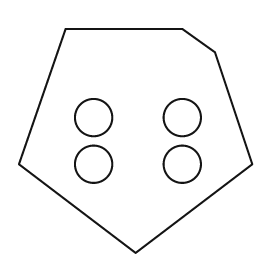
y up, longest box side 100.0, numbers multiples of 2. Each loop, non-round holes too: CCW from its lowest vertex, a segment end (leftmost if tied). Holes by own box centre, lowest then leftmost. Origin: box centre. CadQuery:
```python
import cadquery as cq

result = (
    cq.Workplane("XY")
    .moveTo(0.0, -48.0)
    .lineTo(50.0, -10.0)
    .lineTo(34.0, 38.0)
    .lineTo(20.0, 48.0)
    .lineTo(-30.0, 48.0)
    .lineTo(-50.0, -10.0)
    .close()
    .moveTo(-18.0, -10.0)
    .circle(8.0)
    .moveTo(20.0, -10.0)
    .circle(8.0)
    .moveTo(-18.0, 10.0)
    .circle(8.0)
    .moveTo(20.0, 10.0)
    .circle(8.0)
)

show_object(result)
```